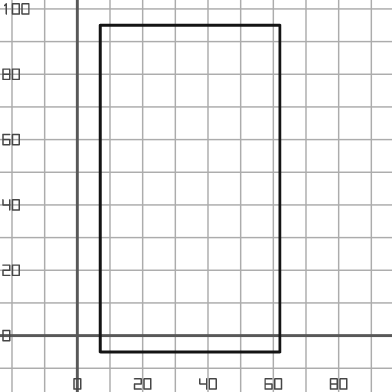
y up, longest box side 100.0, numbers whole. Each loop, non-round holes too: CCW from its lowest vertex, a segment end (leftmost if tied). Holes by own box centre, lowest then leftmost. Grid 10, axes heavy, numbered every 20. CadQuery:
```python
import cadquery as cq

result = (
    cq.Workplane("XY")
    .moveTo(7.0, -5.0)
    .lineTo(62.0, -5.0)
    .lineTo(62.0, 95.0)
    .lineTo(7.0, 95.0)
    .close()
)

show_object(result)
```